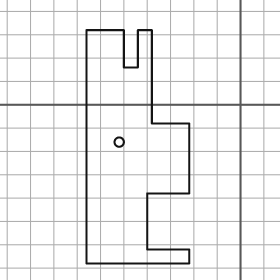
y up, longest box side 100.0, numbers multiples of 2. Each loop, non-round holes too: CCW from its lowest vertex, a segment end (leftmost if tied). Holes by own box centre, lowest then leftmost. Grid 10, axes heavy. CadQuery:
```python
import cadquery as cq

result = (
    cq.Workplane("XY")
    .moveTo(-66.0, -68.0)
    .lineTo(-22.0, -68.0)
    .lineTo(-22.0, -62.0)
    .lineTo(-40.0, -62.0)
    .lineTo(-40.0, -38.0)
    .lineTo(-22.0, -38.0)
    .lineTo(-22.0, -8.0)
    .lineTo(-38.0, -8.0)
    .lineTo(-38.0, 32.0)
    .lineTo(-44.0, 32.0)
    .lineTo(-44.0, 16.0)
    .lineTo(-50.0, 16.0)
    .lineTo(-50.0, 32.0)
    .lineTo(-66.0, 32.0)
    .close()
    .moveTo(-52.0, -16.0)
    .circle(2.0)
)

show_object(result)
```